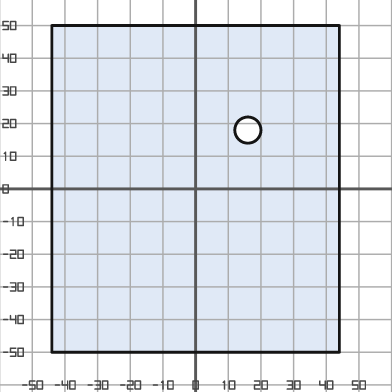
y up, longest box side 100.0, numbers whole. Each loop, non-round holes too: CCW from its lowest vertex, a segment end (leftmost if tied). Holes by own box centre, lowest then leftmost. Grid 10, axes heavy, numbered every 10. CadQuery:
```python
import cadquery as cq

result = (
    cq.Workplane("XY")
    .moveTo(-44.0, -50.0)
    .lineTo(44.0, -50.0)
    .lineTo(44.0, 50.0)
    .lineTo(-44.0, 50.0)
    .close()
    .moveTo(16.0, 18.0)
    .circle(4.0)
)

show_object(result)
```